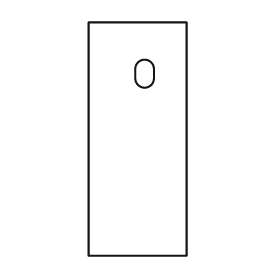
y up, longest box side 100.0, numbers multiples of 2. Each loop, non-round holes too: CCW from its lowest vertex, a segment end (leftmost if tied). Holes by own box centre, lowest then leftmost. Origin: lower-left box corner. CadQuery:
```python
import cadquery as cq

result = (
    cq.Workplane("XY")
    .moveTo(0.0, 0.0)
    .lineTo(42.0, 0.0)
    .lineTo(42.0, 100.0)
    .lineTo(0.0, 100.0)
    .close()
    .moveTo(20.0, 76.0)
    .threePointArc((24.0, 72.0), (28.0, 76.0))
    .lineTo(28.0, 80.0)
    .threePointArc((24.0, 84.0), (20.0, 80.0))
    .close()
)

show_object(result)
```